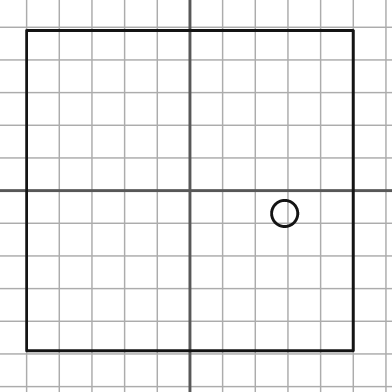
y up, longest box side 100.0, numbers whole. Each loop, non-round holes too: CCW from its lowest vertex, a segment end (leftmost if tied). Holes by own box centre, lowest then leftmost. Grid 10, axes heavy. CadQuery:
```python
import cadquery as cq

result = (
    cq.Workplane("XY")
    .moveTo(-50.0, -49.0)
    .lineTo(50.0, -49.0)
    .lineTo(50.0, 49.0)
    .lineTo(-50.0, 49.0)
    .close()
    .moveTo(29.0, -7.0)
    .circle(4.0)
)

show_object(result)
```